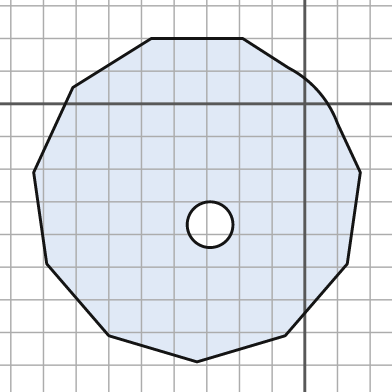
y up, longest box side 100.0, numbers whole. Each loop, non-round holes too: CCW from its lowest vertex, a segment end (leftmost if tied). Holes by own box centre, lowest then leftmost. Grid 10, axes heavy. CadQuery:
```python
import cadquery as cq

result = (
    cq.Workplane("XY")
    .moveTo(-33.0, -79.0)
    .lineTo(-6.0, -71.0)
    .lineTo(13.0, -49.0)
    .lineTo(17.0, -21.0)
    .lineTo(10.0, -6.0)
    .threePointArc((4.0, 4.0), (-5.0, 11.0))
    .lineTo(-19.0, 20.0)
    .lineTo(-47.0, 20.0)
    .lineTo(-71.0, 5.0)
    .lineTo(-83.0, -21.0)
    .lineTo(-79.0, -49.0)
    .lineTo(-60.0, -71.0)
    .close()
    .moveTo(-29.0, -37.0)
    .circle(7.0)
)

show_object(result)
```